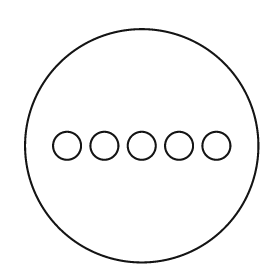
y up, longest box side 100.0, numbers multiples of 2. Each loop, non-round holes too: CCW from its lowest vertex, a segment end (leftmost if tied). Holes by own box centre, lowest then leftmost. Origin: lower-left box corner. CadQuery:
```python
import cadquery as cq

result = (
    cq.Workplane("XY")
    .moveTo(50.0, 50.0)
    .circle(50.0)
    .moveTo(18.0, 50.0)
    .circle(6.0)
    .moveTo(34.0, 50.0)
    .circle(6.0)
    .moveTo(50.0, 50.0)
    .circle(6.0)
    .moveTo(66.0, 50.0)
    .circle(6.0)
    .moveTo(82.0, 50.0)
    .circle(6.0)
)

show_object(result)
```